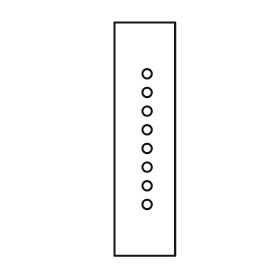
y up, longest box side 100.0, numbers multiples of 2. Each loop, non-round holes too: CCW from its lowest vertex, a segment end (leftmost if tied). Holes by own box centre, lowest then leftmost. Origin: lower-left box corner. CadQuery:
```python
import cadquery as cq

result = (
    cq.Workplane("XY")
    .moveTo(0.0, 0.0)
    .lineTo(26.0, 0.0)
    .lineTo(26.0, 100.0)
    .lineTo(0.0, 100.0)
    .close()
    .moveTo(14.0, 22.0)
    .circle(2.0)
    .moveTo(14.0, 30.0)
    .circle(2.0)
    .moveTo(14.0, 38.0)
    .circle(2.0)
    .moveTo(14.0, 46.0)
    .circle(2.0)
    .moveTo(14.0, 54.0)
    .circle(2.0)
    .moveTo(14.0, 62.0)
    .circle(2.0)
    .moveTo(14.0, 70.0)
    .circle(2.0)
    .moveTo(14.0, 78.0)
    .circle(2.0)
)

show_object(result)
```